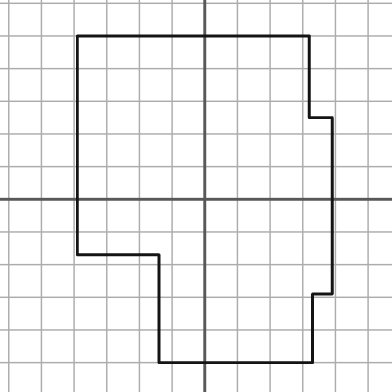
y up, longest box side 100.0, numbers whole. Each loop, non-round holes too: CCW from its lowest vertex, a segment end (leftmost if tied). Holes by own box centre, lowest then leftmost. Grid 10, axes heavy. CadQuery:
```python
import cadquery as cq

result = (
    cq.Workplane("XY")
    .moveTo(-14.0, -50.0)
    .lineTo(33.0, -50.0)
    .lineTo(33.0, -29.0)
    .lineTo(39.0, -29.0)
    .lineTo(39.0, 25.0)
    .lineTo(32.0, 25.0)
    .lineTo(32.0, 50.0)
    .lineTo(-39.0, 50.0)
    .lineTo(-39.0, -17.0)
    .lineTo(-14.0, -17.0)
    .close()
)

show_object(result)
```